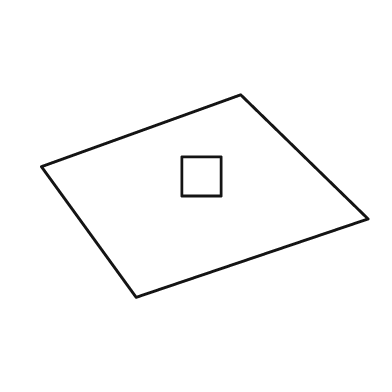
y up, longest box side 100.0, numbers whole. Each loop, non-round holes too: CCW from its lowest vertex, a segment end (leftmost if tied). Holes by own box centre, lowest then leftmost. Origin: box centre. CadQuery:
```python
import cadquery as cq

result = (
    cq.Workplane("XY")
    .moveTo(-21.0, -31.0)
    .lineTo(50.0, -7.0)
    .lineTo(11.0, 31.0)
    .lineTo(-50.0, 9.0)
    .close()
    .moveTo(-7.0, 0.0)
    .lineTo(5.0, 0.0)
    .lineTo(5.0, 12.0)
    .lineTo(-7.0, 12.0)
    .close()
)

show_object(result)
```